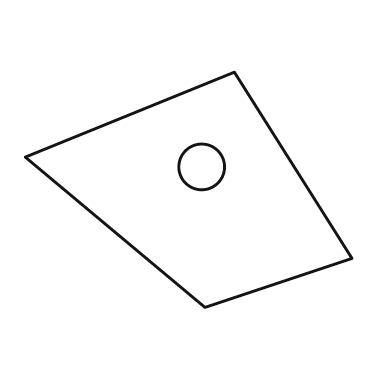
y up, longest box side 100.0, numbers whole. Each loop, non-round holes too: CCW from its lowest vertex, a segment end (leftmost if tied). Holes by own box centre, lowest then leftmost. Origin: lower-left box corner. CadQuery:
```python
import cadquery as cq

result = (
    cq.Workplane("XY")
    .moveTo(55.0, 0.0)
    .lineTo(100.0, 15.0)
    .lineTo(64.0, 72.0)
    .lineTo(0.0, 46.0)
    .close()
    .moveTo(54.0, 43.0)
    .circle(7.0)
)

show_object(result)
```